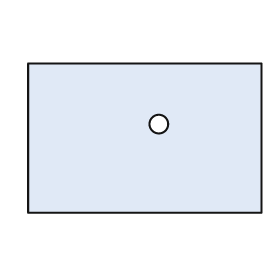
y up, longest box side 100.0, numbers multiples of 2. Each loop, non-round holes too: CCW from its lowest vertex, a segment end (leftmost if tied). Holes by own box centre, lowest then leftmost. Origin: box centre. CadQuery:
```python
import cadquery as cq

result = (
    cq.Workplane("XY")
    .moveTo(-50.0, -32.0)
    .lineTo(50.0, -32.0)
    .lineTo(50.0, 32.0)
    .lineTo(-50.0, 32.0)
    .close()
    .moveTo(6.0, 6.0)
    .circle(4.0)
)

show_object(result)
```